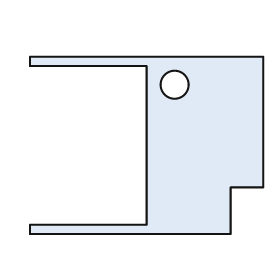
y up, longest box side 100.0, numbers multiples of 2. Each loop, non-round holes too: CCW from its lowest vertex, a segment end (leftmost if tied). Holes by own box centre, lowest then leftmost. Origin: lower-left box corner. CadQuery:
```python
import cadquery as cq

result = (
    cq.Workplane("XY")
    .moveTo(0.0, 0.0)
    .lineTo(86.0, 0.0)
    .lineTo(86.0, 20.0)
    .lineTo(100.0, 20.0)
    .lineTo(100.0, 76.0)
    .lineTo(0.0, 76.0)
    .lineTo(0.0, 72.0)
    .lineTo(50.0, 72.0)
    .lineTo(50.0, 4.0)
    .lineTo(0.0, 4.0)
    .close()
    .moveTo(62.0, 64.0)
    .circle(6.0)
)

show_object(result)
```